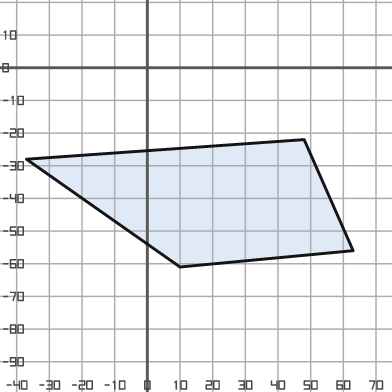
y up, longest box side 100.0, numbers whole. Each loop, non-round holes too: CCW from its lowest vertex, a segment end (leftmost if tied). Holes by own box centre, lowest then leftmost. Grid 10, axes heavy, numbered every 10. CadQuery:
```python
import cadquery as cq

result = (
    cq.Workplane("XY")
    .moveTo(10.0, -61.0)
    .lineTo(63.0, -56.0)
    .lineTo(48.0, -22.0)
    .lineTo(-37.0, -28.0)
    .close()
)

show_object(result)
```